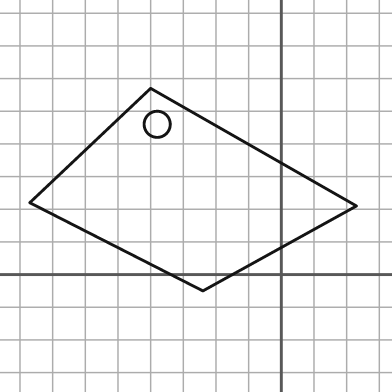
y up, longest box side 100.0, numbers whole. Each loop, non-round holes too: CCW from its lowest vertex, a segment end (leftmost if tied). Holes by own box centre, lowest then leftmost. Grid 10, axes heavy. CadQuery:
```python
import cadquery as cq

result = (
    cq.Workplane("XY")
    .moveTo(-24.0, -5.0)
    .lineTo(23.0, 21.0)
    .lineTo(-40.0, 57.0)
    .lineTo(-77.0, 22.0)
    .close()
    .moveTo(-38.0, 46.0)
    .circle(4.0)
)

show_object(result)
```